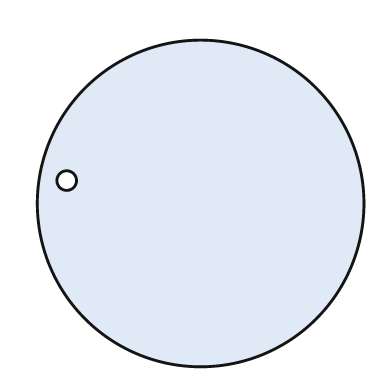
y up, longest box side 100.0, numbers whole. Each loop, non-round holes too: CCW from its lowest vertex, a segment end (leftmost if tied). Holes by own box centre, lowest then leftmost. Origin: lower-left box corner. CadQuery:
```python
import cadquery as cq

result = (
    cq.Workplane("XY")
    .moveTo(50.0, 50.0)
    .circle(50.0)
    .moveTo(9.0, 57.0)
    .circle(3.0)
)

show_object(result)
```